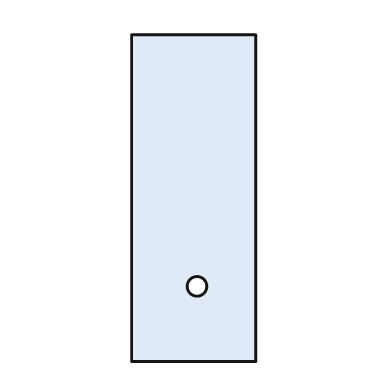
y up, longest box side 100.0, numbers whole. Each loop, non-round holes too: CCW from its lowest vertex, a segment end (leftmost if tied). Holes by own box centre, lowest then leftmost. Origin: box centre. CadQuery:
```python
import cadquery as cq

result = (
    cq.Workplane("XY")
    .moveTo(-19.0, -50.0)
    .lineTo(19.0, -50.0)
    .lineTo(19.0, 50.0)
    .lineTo(-19.0, 50.0)
    .close()
    .moveTo(1.0, -27.0)
    .circle(3.0)
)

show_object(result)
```